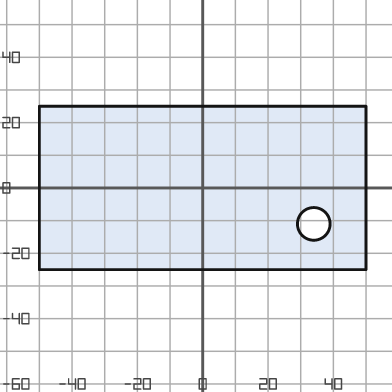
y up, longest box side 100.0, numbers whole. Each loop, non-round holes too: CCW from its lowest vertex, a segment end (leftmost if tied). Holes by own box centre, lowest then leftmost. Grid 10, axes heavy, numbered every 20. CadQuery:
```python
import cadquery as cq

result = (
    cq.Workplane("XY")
    .moveTo(-50.0, -25.0)
    .lineTo(50.0, -25.0)
    .lineTo(50.0, 25.0)
    .lineTo(-50.0, 25.0)
    .close()
    .moveTo(34.0, -11.0)
    .circle(5.0)
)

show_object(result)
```